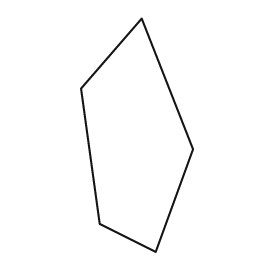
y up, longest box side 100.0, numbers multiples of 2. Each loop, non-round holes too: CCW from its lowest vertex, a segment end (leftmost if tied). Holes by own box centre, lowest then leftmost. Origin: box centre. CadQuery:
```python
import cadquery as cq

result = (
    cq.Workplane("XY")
    .moveTo(8.0, -50.0)
    .lineTo(24.0, -6.0)
    .lineTo(2.0, 50.0)
    .lineTo(-24.0, 20.0)
    .lineTo(-16.0, -38.0)
    .close()
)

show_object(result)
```